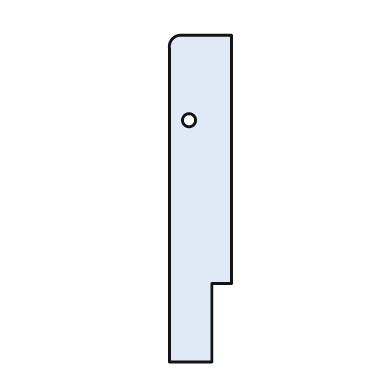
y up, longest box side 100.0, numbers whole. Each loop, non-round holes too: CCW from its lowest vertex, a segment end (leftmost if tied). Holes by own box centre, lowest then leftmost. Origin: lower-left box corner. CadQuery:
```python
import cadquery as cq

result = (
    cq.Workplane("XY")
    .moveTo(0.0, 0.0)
    .lineTo(13.0, 0.0)
    .lineTo(13.0, 24.0)
    .lineTo(19.0, 24.0)
    .lineTo(19.0, 100.0)
    .lineTo(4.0, 100.0)
    .threePointArc((1.0, 99.0), (0.0, 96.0))
    .close()
    .moveTo(6.0, 74.0)
    .circle(2.0)
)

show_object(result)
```